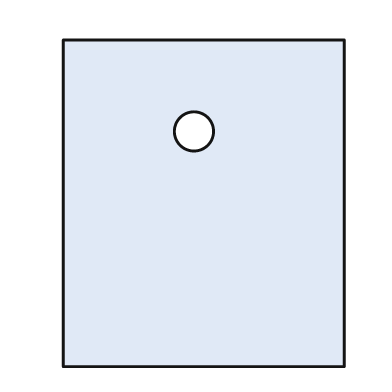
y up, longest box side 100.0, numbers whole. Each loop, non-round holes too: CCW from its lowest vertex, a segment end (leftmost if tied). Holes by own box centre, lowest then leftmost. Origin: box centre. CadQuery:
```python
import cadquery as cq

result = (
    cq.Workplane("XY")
    .moveTo(-43.0, -50.0)
    .lineTo(43.0, -50.0)
    .lineTo(43.0, 50.0)
    .lineTo(-43.0, 50.0)
    .close()
    .moveTo(-3.0, 22.0)
    .circle(6.0)
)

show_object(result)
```